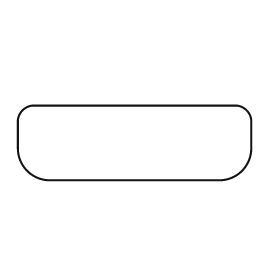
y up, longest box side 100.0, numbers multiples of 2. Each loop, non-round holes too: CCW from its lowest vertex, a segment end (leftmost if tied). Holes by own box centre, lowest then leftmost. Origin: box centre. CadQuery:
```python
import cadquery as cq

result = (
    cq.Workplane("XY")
    .moveTo(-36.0, -16.0)
    .lineTo(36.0, -16.0)
    .threePointArc((46.0, -12.0), (50.0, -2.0))
    .lineTo(50.0, 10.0)
    .threePointArc((48.0, 14.0), (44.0, 16.0))
    .lineTo(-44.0, 16.0)
    .threePointArc((-48.0, 14.0), (-50.0, 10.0))
    .lineTo(-50.0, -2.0)
    .threePointArc((-46.0, -12.0), (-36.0, -16.0))
    .close()
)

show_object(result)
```